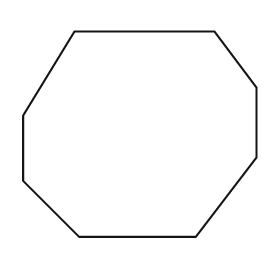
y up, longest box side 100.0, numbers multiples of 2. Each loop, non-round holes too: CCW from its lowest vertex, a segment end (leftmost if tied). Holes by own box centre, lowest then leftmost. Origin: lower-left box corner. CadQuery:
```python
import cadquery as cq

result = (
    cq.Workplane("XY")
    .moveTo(24.0, 0.0)
    .lineTo(74.0, 0.0)
    .lineTo(100.0, 34.0)
    .lineTo(100.0, 64.0)
    .lineTo(82.0, 88.0)
    .lineTo(22.0, 88.0)
    .lineTo(0.0, 52.0)
    .lineTo(0.0, 24.0)
    .close()
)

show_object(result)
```